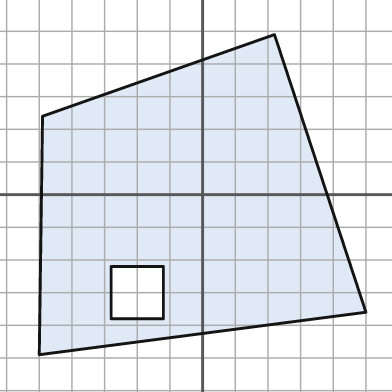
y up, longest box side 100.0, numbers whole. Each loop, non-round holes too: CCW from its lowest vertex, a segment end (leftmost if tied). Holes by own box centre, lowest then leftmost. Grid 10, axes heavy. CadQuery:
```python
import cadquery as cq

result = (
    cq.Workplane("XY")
    .moveTo(-50.0, -49.0)
    .lineTo(50.0, -36.0)
    .lineTo(22.0, 49.0)
    .lineTo(-49.0, 24.0)
    .close()
    .moveTo(-28.0, -38.0)
    .lineTo(-12.0, -38.0)
    .lineTo(-12.0, -22.0)
    .lineTo(-28.0, -22.0)
    .close()
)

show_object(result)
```